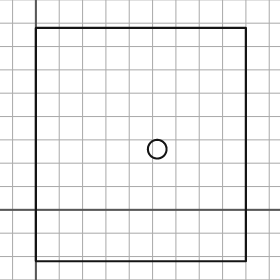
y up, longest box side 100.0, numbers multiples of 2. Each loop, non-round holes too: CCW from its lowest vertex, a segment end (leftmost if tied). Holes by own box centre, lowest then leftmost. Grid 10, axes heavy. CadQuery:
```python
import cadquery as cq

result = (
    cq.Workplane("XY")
    .moveTo(0.0, -22.0)
    .lineTo(90.0, -22.0)
    .lineTo(90.0, 78.0)
    .lineTo(0.0, 78.0)
    .close()
    .moveTo(52.0, 26.0)
    .circle(4.0)
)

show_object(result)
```